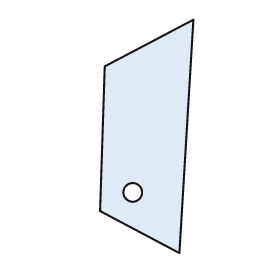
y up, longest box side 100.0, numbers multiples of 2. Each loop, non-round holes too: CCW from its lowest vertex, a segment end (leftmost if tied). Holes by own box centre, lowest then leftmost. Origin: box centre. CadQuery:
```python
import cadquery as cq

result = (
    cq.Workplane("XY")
    .moveTo(14.0, -50.0)
    .lineTo(20.0, 50.0)
    .lineTo(-18.0, 30.0)
    .lineTo(-20.0, -32.0)
    .close()
    .moveTo(-6.0, -24.0)
    .circle(4.0)
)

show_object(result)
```